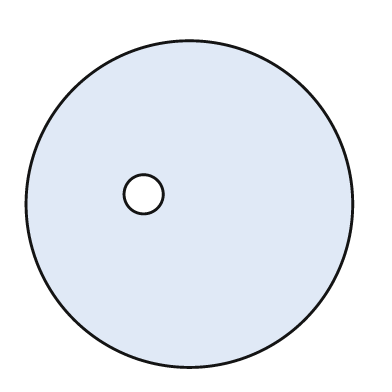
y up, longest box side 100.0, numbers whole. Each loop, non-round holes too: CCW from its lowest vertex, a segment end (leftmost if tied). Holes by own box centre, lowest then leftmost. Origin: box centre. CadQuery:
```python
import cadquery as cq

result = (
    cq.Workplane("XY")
    .moveTo(0.0, 0.0)
    .circle(50.0)
    .moveTo(-14.0, 3.0)
    .circle(6.0)
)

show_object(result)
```